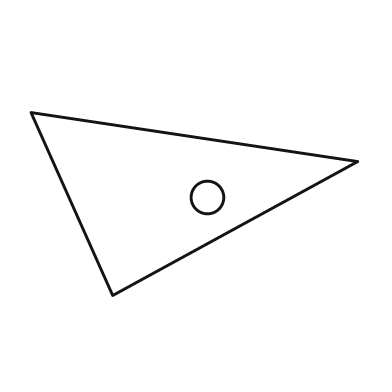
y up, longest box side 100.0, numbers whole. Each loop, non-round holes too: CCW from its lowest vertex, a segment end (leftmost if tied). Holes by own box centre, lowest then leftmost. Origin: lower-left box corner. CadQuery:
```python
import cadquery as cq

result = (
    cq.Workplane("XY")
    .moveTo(25.0, 0.0)
    .lineTo(100.0, 41.0)
    .lineTo(0.0, 56.0)
    .close()
    .moveTo(54.0, 30.0)
    .circle(5.0)
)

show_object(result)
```